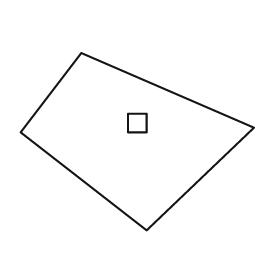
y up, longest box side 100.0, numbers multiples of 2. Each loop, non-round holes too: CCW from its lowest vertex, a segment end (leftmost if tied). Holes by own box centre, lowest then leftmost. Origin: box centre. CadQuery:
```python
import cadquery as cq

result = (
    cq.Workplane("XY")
    .moveTo(4.0, -38.0)
    .lineTo(50.0, 6.0)
    .lineTo(-24.0, 38.0)
    .lineTo(-50.0, 4.0)
    .close()
    .moveTo(-4.0, 4.0)
    .lineTo(4.0, 4.0)
    .lineTo(4.0, 12.0)
    .lineTo(-4.0, 12.0)
    .close()
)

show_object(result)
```